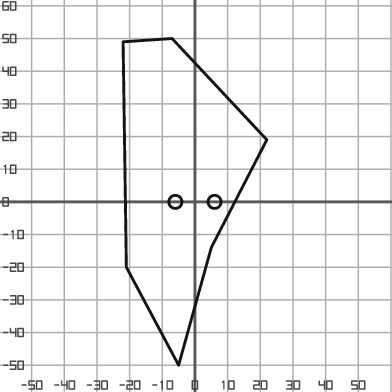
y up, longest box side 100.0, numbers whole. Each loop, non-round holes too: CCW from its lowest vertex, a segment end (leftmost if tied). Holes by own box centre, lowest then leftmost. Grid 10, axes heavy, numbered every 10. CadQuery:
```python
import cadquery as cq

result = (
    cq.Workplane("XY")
    .moveTo(-5.0, -50.0)
    .lineTo(5.0, -14.0)
    .lineTo(22.0, 19.0)
    .lineTo(-7.0, 50.0)
    .lineTo(-22.0, 49.0)
    .lineTo(-21.0, -20.0)
    .close()
    .moveTo(-6.0, 0.0)
    .circle(2.0)
    .moveTo(6.0, 0.0)
    .circle(2.0)
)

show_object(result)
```